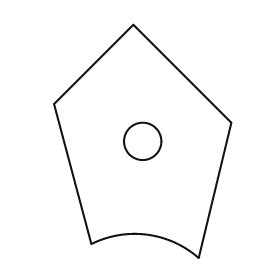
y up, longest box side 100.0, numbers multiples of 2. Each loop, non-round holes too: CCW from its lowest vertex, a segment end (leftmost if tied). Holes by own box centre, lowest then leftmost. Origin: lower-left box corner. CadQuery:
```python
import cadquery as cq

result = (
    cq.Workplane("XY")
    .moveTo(62.0, 0.0)
    .lineTo(76.0, 58.0)
    .lineTo(34.0, 100.0)
    .lineTo(0.0, 66.0)
    .lineTo(16.0, 6.0)
    .threePointArc((40.0, 10.0), (62.0, 0.0))
    .close()
    .moveTo(38.0, 50.0)
    .circle(8.0)
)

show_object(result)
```